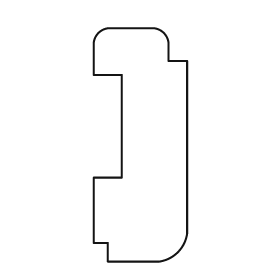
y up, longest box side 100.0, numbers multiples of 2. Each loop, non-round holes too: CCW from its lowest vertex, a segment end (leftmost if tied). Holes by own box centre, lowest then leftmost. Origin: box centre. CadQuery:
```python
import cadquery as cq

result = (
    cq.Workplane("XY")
    .moveTo(-14.0, -50.0)
    .lineTo(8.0, -50.0)
    .threePointArc((16.0, -46.0), (20.0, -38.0))
    .lineTo(20.0, 36.0)
    .lineTo(12.0, 36.0)
    .lineTo(12.0, 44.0)
    .threePointArc((10.0, 48.0), (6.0, 50.0))
    .lineTo(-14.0, 50.0)
    .threePointArc((-18.0, 48.0), (-20.0, 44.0))
    .lineTo(-20.0, 30.0)
    .lineTo(-8.0, 30.0)
    .lineTo(-8.0, -14.0)
    .lineTo(-20.0, -14.0)
    .lineTo(-20.0, -42.0)
    .lineTo(-14.0, -42.0)
    .close()
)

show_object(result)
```